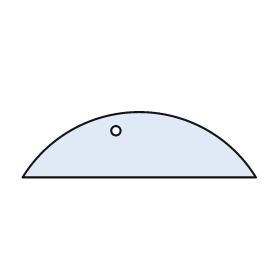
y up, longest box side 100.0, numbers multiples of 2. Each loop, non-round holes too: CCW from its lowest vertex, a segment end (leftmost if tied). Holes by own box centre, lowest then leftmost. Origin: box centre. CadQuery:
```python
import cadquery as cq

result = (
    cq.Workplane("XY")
    .moveTo(-50.0, -14.0)
    .lineTo(50.0, -14.0)
    .threePointArc((0.0, 14.0), (-50.0, -14.0))
    .close()
    .moveTo(-10.0, 6.0)
    .circle(2.0)
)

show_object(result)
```